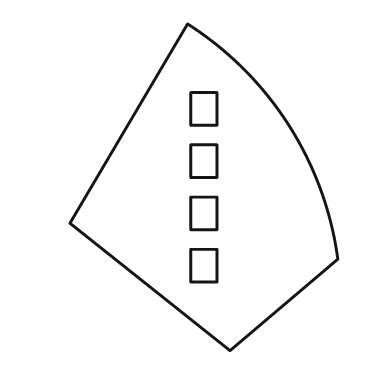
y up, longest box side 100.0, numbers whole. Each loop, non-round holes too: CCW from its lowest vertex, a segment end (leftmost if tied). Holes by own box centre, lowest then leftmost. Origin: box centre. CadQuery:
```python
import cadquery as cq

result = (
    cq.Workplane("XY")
    .moveTo(8.0, -50.0)
    .lineTo(41.0, -22.0)
    .threePointArc((26.0, 19.0), (-5.0, 50.0))
    .lineTo(-41.0, -11.0)
    .close()
    .moveTo(-4.0, -29.0)
    .lineTo(4.0, -29.0)
    .lineTo(4.0, -19.0)
    .lineTo(-4.0, -19.0)
    .close()
    .moveTo(-4.0, -13.0)
    .lineTo(4.0, -13.0)
    .lineTo(4.0, -3.0)
    .lineTo(-4.0, -3.0)
    .close()
    .moveTo(-4.0, 3.0)
    .lineTo(4.0, 3.0)
    .lineTo(4.0, 13.0)
    .lineTo(-4.0, 13.0)
    .close()
    .moveTo(-4.0, 19.0)
    .lineTo(4.0, 19.0)
    .lineTo(4.0, 29.0)
    .lineTo(-4.0, 29.0)
    .close()
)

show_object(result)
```